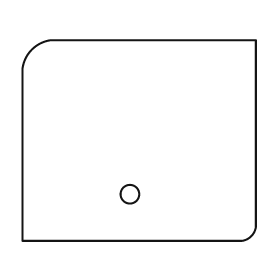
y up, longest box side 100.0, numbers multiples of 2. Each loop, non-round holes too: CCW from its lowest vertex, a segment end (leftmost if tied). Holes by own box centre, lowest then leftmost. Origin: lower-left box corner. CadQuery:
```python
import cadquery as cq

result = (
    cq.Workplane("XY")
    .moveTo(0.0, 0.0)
    .lineTo(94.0, 0.0)
    .threePointArc((98.0, 2.0), (100.0, 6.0))
    .lineTo(100.0, 86.0)
    .lineTo(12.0, 86.0)
    .threePointArc((4.0, 82.0), (0.0, 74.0))
    .close()
    .moveTo(46.0, 20.0)
    .circle(4.0)
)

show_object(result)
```